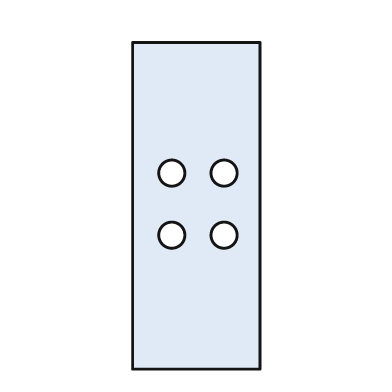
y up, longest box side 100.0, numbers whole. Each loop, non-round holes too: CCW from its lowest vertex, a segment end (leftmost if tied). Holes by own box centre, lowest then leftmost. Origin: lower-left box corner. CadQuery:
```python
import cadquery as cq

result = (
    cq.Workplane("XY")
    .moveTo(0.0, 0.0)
    .lineTo(39.0, 0.0)
    .lineTo(39.0, 100.0)
    .lineTo(0.0, 100.0)
    .close()
    .moveTo(12.0, 41.0)
    .circle(4.0)
    .moveTo(28.0, 41.0)
    .circle(4.0)
    .moveTo(12.0, 60.0)
    .circle(4.0)
    .moveTo(28.0, 60.0)
    .circle(4.0)
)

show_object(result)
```